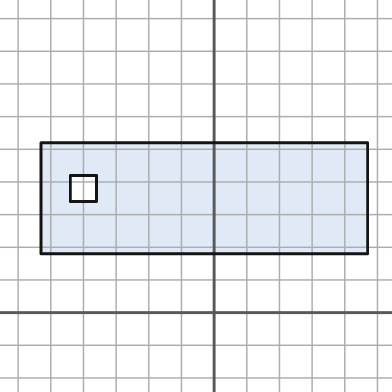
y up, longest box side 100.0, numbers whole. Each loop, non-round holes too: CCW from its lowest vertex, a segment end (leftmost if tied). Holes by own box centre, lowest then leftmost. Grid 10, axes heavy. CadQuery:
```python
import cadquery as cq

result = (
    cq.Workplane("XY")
    .moveTo(-53.0, 18.0)
    .lineTo(47.0, 18.0)
    .lineTo(47.0, 52.0)
    .lineTo(-53.0, 52.0)
    .close()
    .moveTo(-44.0, 34.0)
    .lineTo(-36.0, 34.0)
    .lineTo(-36.0, 42.0)
    .lineTo(-44.0, 42.0)
    .close()
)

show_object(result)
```